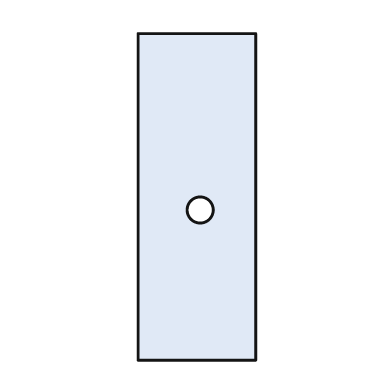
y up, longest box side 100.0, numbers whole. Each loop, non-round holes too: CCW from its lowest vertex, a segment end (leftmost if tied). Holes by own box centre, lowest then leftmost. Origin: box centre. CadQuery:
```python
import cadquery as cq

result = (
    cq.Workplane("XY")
    .moveTo(-18.0, -50.0)
    .lineTo(18.0, -50.0)
    .lineTo(18.0, 50.0)
    .lineTo(-18.0, 50.0)
    .close()
    .moveTo(1.0, -4.0)
    .circle(4.0)
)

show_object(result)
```